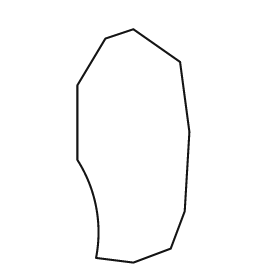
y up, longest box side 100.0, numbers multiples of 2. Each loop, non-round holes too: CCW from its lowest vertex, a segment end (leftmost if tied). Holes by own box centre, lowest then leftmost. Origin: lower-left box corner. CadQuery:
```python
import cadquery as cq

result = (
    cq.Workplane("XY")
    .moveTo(24.0, 0.0)
    .lineTo(40.0, 6.0)
    .lineTo(46.0, 22.0)
    .lineTo(48.0, 56.0)
    .lineTo(44.0, 86.0)
    .lineTo(24.0, 100.0)
    .lineTo(12.0, 96.0)
    .lineTo(0.0, 76.0)
    .lineTo(0.0, 44.0)
    .threePointArc((8.0, 24.0), (8.0, 2.0))
    .close()
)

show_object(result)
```